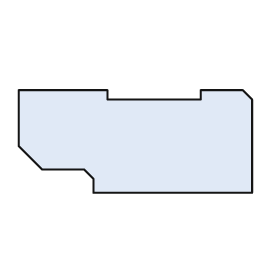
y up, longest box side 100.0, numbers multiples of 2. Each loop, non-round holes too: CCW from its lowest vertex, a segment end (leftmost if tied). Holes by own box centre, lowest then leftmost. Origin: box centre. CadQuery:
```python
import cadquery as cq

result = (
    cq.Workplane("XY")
    .moveTo(-18.0, -22.0)
    .lineTo(50.0, -22.0)
    .lineTo(50.0, 18.0)
    .lineTo(46.0, 22.0)
    .lineTo(28.0, 22.0)
    .lineTo(28.0, 18.0)
    .lineTo(-12.0, 18.0)
    .lineTo(-12.0, 22.0)
    .lineTo(-50.0, 22.0)
    .lineTo(-50.0, -2.0)
    .lineTo(-40.0, -12.0)
    .lineTo(-22.0, -12.0)
    .lineTo(-18.0, -16.0)
    .close()
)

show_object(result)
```